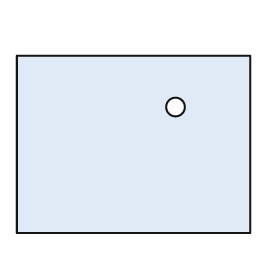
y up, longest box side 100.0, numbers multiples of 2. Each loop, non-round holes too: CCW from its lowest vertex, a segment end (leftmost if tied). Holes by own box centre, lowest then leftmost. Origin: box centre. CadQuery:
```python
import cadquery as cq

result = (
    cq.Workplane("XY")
    .moveTo(-50.0, -38.0)
    .lineTo(50.0, -38.0)
    .lineTo(50.0, 38.0)
    .lineTo(-50.0, 38.0)
    .close()
    .moveTo(18.0, 16.0)
    .circle(4.0)
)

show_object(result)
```